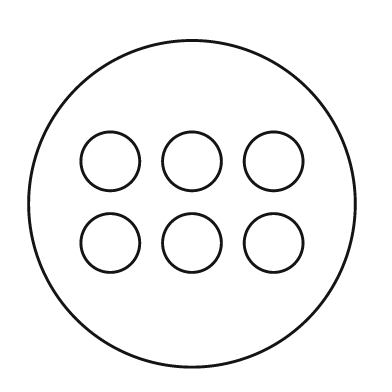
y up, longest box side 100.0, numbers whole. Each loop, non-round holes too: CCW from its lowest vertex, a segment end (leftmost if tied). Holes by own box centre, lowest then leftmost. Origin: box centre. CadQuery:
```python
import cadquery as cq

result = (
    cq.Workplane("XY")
    .moveTo(0.0, 0.0)
    .circle(50.0)
    .moveTo(-25.0, -12.0)
    .circle(9.0)
    .moveTo(0.0, -12.0)
    .circle(9.0)
    .moveTo(25.0, -12.0)
    .circle(9.0)
    .moveTo(-25.0, 13.0)
    .circle(9.0)
    .moveTo(0.0, 13.0)
    .circle(9.0)
    .moveTo(25.0, 13.0)
    .circle(9.0)
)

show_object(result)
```